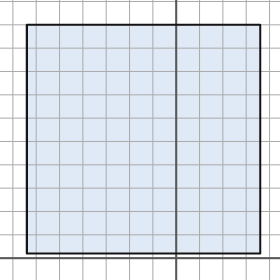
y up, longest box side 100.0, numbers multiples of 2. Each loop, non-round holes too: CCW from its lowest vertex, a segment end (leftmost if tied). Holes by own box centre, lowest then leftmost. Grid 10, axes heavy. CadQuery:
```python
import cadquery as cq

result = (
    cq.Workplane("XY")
    .moveTo(-64.0, 2.0)
    .lineTo(36.0, 2.0)
    .lineTo(36.0, 100.0)
    .lineTo(-64.0, 100.0)
    .close()
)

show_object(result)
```